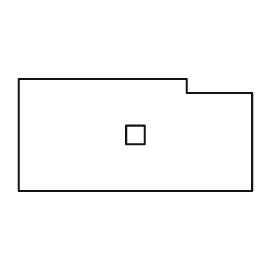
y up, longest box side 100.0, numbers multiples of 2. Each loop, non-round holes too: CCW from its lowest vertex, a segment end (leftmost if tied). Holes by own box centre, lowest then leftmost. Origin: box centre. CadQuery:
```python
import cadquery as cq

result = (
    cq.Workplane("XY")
    .moveTo(-50.0, -24.0)
    .lineTo(50.0, -24.0)
    .lineTo(50.0, 18.0)
    .lineTo(22.0, 18.0)
    .lineTo(22.0, 24.0)
    .lineTo(-50.0, 24.0)
    .close()
    .moveTo(-4.0, -4.0)
    .lineTo(4.0, -4.0)
    .lineTo(4.0, 4.0)
    .lineTo(-4.0, 4.0)
    .close()
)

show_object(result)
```